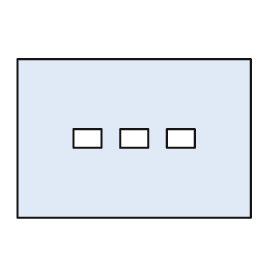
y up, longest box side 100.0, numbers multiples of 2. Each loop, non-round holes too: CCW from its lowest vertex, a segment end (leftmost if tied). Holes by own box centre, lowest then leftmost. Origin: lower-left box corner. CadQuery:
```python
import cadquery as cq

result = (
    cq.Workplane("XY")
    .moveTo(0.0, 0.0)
    .lineTo(100.0, 0.0)
    .lineTo(100.0, 68.0)
    .lineTo(0.0, 68.0)
    .close()
    .moveTo(24.0, 30.0)
    .lineTo(36.0, 30.0)
    .lineTo(36.0, 38.0)
    .lineTo(24.0, 38.0)
    .close()
    .moveTo(44.0, 30.0)
    .lineTo(56.0, 30.0)
    .lineTo(56.0, 38.0)
    .lineTo(44.0, 38.0)
    .close()
    .moveTo(64.0, 30.0)
    .lineTo(76.0, 30.0)
    .lineTo(76.0, 38.0)
    .lineTo(64.0, 38.0)
    .close()
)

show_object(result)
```